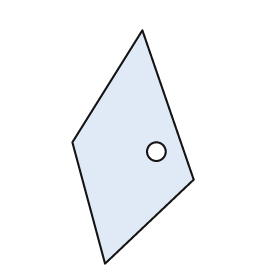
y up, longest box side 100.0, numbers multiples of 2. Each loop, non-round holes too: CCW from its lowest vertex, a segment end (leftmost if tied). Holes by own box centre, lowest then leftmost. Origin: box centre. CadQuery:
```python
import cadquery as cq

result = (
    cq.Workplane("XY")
    .moveTo(-12.0, -50.0)
    .lineTo(26.0, -14.0)
    .lineTo(4.0, 50.0)
    .lineTo(-26.0, 2.0)
    .close()
    .moveTo(10.0, -2.0)
    .circle(4.0)
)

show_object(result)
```